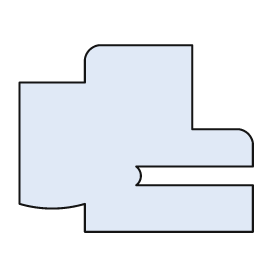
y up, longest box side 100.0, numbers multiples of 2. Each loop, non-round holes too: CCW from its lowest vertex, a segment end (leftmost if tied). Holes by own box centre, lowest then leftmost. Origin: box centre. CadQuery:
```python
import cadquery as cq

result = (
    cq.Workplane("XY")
    .moveTo(-22.0, -40.0)
    .lineTo(50.0, -40.0)
    .lineTo(50.0, -20.0)
    .lineTo(0.0, -20.0)
    .threePointArc((2.0, -16.0), (0.0, -12.0))
    .lineTo(50.0, -12.0)
    .lineTo(50.0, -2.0)
    .threePointArc((48.0, 2.0), (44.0, 4.0))
    .lineTo(24.0, 4.0)
    .lineTo(24.0, 40.0)
    .lineTo(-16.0, 40.0)
    .threePointArc((-20.0, 38.0), (-22.0, 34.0))
    .lineTo(-22.0, 24.0)
    .lineTo(-50.0, 24.0)
    .lineTo(-50.0, -28.0)
    .threePointArc((-36.0, -30.0), (-22.0, -28.0))
    .close()
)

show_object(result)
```